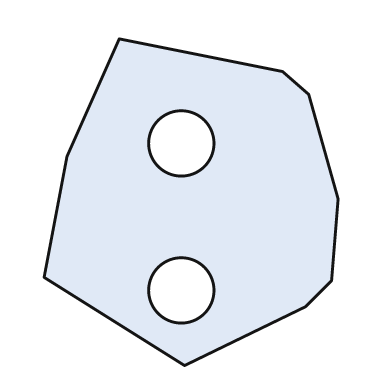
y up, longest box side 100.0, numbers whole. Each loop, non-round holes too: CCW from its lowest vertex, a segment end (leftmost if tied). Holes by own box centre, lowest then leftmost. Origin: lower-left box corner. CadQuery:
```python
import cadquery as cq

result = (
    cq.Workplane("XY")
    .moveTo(43.0, 0.0)
    .lineTo(80.0, 18.0)
    .lineTo(88.0, 26.0)
    .lineTo(90.0, 51.0)
    .lineTo(81.0, 83.0)
    .lineTo(73.0, 90.0)
    .lineTo(23.0, 100.0)
    .lineTo(7.0, 64.0)
    .lineTo(0.0, 27.0)
    .close()
    .moveTo(42.0, 23.0)
    .circle(10.0)
    .moveTo(42.0, 68.0)
    .circle(10.0)
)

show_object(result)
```